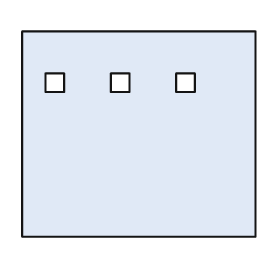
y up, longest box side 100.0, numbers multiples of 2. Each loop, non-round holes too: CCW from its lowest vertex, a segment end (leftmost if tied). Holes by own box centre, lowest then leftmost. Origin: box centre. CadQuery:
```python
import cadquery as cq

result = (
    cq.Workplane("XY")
    .moveTo(-50.0, -44.0)
    .lineTo(50.0, -44.0)
    .lineTo(50.0, 44.0)
    .lineTo(-50.0, 44.0)
    .close()
    .moveTo(-40.0, 18.0)
    .lineTo(-32.0, 18.0)
    .lineTo(-32.0, 26.0)
    .lineTo(-40.0, 26.0)
    .close()
    .moveTo(-12.0, 18.0)
    .lineTo(-4.0, 18.0)
    .lineTo(-4.0, 26.0)
    .lineTo(-12.0, 26.0)
    .close()
    .moveTo(16.0, 18.0)
    .lineTo(24.0, 18.0)
    .lineTo(24.0, 26.0)
    .lineTo(16.0, 26.0)
    .close()
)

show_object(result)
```